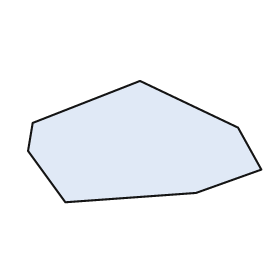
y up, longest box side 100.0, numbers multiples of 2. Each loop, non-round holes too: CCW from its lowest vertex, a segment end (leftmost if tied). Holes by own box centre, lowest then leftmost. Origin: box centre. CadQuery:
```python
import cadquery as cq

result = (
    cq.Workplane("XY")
    .moveTo(-34.0, -26.0)
    .lineTo(22.0, -22.0)
    .lineTo(50.0, -12.0)
    .lineTo(40.0, 6.0)
    .lineTo(-2.0, 26.0)
    .lineTo(-48.0, 8.0)
    .lineTo(-50.0, -4.0)
    .close()
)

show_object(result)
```